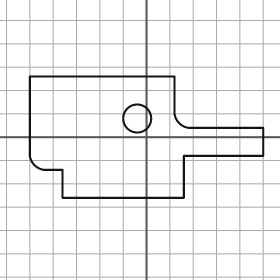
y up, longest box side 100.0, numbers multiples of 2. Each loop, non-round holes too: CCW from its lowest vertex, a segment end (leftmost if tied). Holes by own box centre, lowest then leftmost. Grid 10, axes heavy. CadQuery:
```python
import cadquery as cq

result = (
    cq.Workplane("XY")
    .moveTo(-36.0, -26.0)
    .lineTo(16.0, -26.0)
    .lineTo(16.0, -8.0)
    .lineTo(50.0, -8.0)
    .lineTo(50.0, 4.0)
    .lineTo(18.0, 4.0)
    .threePointArc((14.0, 6.0), (12.0, 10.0))
    .lineTo(12.0, 26.0)
    .lineTo(-50.0, 26.0)
    .lineTo(-50.0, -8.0)
    .threePointArc((-48.0, -12.0), (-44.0, -14.0))
    .lineTo(-36.0, -14.0)
    .close()
    .moveTo(-4.0, 8.0)
    .circle(6.0)
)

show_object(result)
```